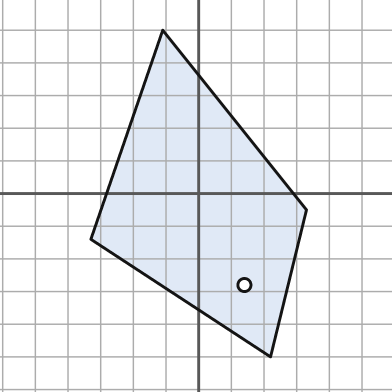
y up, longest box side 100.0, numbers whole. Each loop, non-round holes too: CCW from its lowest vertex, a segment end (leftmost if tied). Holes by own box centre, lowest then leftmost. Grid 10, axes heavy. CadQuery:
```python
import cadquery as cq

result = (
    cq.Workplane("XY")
    .moveTo(22.0, -50.0)
    .lineTo(33.0, -5.0)
    .lineTo(-11.0, 50.0)
    .lineTo(-33.0, -14.0)
    .close()
    .moveTo(14.0, -28.0)
    .circle(2.0)
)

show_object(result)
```